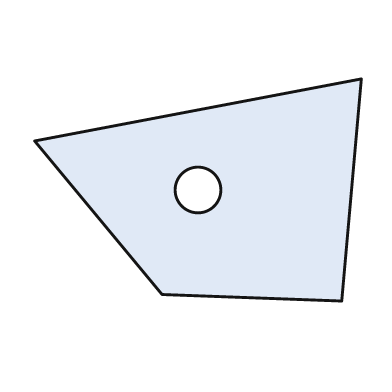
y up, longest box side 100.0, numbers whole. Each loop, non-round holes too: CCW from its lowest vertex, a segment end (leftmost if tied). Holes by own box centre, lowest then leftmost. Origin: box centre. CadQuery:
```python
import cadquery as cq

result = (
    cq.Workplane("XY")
    .moveTo(44.0, -34.0)
    .lineTo(50.0, 34.0)
    .lineTo(-50.0, 15.0)
    .lineTo(-11.0, -32.0)
    .close()
    .moveTo(0.0, 0.0)
    .circle(7.0)
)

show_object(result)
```